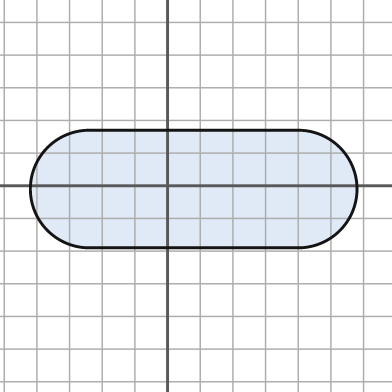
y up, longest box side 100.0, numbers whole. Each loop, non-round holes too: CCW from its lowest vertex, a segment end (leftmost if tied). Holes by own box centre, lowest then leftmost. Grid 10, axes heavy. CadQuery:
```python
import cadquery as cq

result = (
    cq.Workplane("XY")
    .moveTo(-24.0, -19.0)
    .lineTo(40.0, -19.0)
    .threePointArc((58.0, -1.0), (40.0, 17.0))
    .lineTo(-24.0, 17.0)
    .threePointArc((-42.0, -1.0), (-24.0, -19.0))
    .close()
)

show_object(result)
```